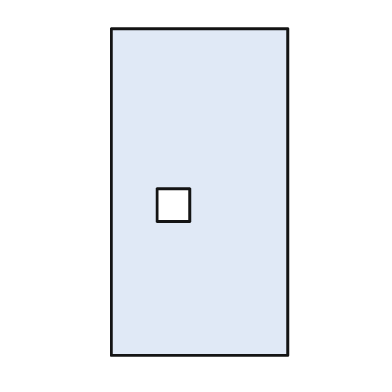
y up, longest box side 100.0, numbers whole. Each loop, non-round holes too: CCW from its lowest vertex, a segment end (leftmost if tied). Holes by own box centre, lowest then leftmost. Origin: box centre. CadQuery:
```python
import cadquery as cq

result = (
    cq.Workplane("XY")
    .moveTo(-27.0, -50.0)
    .lineTo(27.0, -50.0)
    .lineTo(27.0, 50.0)
    .lineTo(-27.0, 50.0)
    .close()
    .moveTo(-13.0, -9.0)
    .lineTo(-3.0, -9.0)
    .lineTo(-3.0, 1.0)
    .lineTo(-13.0, 1.0)
    .close()
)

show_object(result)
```